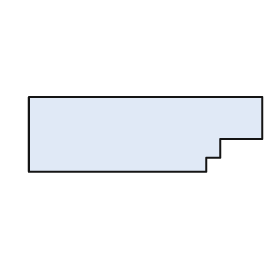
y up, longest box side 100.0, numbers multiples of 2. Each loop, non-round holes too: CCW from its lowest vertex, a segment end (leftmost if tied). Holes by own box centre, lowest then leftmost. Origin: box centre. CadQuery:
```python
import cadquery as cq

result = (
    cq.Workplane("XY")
    .moveTo(-50.0, -16.0)
    .lineTo(26.0, -16.0)
    .lineTo(26.0, -10.0)
    .lineTo(32.0, -10.0)
    .lineTo(32.0, -2.0)
    .lineTo(50.0, -2.0)
    .lineTo(50.0, 16.0)
    .lineTo(-50.0, 16.0)
    .close()
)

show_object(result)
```